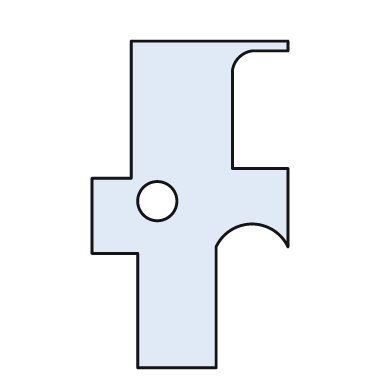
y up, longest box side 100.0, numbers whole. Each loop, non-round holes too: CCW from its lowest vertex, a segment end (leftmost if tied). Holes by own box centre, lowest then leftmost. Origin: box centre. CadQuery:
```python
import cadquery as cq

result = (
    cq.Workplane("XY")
    .moveTo(-16.0, -50.0)
    .lineTo(8.0, -50.0)
    .lineTo(8.0, -13.0)
    .threePointArc((19.0, -6.0), (30.0, -13.0))
    .lineTo(30.0, 11.0)
    .lineTo(13.0, 11.0)
    .lineTo(13.0, 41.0)
    .threePointArc((15.0, 45.0), (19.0, 47.0))
    .lineTo(30.0, 47.0)
    .lineTo(30.0, 50.0)
    .lineTo(-18.0, 50.0)
    .lineTo(-18.0, 8.0)
    .lineTo(-30.0, 8.0)
    .lineTo(-30.0, -15.0)
    .lineTo(-16.0, -15.0)
    .close()
    .moveTo(-10.0, 1.0)
    .circle(6.0)
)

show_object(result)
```